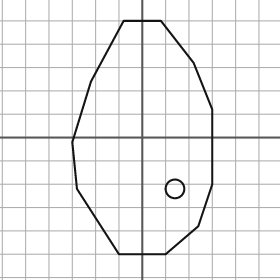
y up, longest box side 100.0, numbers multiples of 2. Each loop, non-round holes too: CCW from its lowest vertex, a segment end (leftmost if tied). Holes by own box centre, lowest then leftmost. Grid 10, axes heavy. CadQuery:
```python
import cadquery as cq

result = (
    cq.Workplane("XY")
    .moveTo(-10.0, -50.0)
    .lineTo(10.0, -50.0)
    .lineTo(24.0, -38.0)
    .lineTo(30.0, -20.0)
    .lineTo(30.0, 12.0)
    .lineTo(22.0, 32.0)
    .lineTo(8.0, 50.0)
    .lineTo(-8.0, 50.0)
    .lineTo(-22.0, 24.0)
    .lineTo(-30.0, -2.0)
    .lineTo(-28.0, -22.0)
    .close()
    .moveTo(14.0, -22.0)
    .circle(4.0)
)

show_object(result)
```